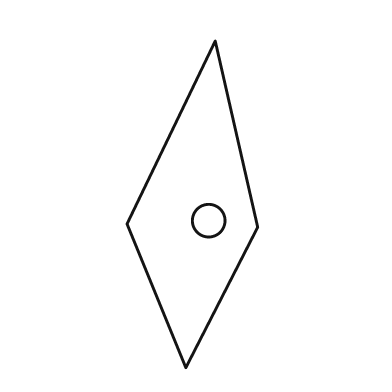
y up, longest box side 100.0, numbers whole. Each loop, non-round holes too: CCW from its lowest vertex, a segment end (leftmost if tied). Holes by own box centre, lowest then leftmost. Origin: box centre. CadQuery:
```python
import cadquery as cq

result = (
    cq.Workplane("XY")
    .moveTo(-2.0, -50.0)
    .lineTo(20.0, -7.0)
    .lineTo(7.0, 50.0)
    .lineTo(-20.0, -6.0)
    .close()
    .moveTo(5.0, -5.0)
    .circle(5.0)
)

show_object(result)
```